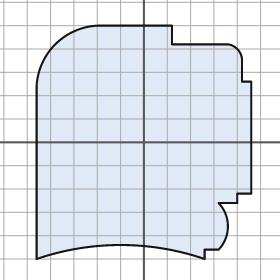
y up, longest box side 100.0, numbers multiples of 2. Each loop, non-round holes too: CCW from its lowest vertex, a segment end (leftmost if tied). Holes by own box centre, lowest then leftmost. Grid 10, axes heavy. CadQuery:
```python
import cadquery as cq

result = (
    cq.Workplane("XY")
    .moveTo(-46.0, -50.0)
    .threePointArc((-10.0, -44.0), (26.0, -50.0))
    .lineTo(26.0, -46.0)
    .lineTo(32.0, -46.0)
    .threePointArc((36.0, -36.0), (32.0, -26.0))
    .lineTo(40.0, -26.0)
    .lineTo(40.0, -22.0)
    .lineTo(46.0, -22.0)
    .lineTo(46.0, 26.0)
    .lineTo(42.0, 26.0)
    .lineTo(42.0, 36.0)
    .threePointArc((40.0, 40.0), (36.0, 42.0))
    .lineTo(12.0, 42.0)
    .lineTo(12.0, 50.0)
    .lineTo(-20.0, 50.0)
    .threePointArc((-38.0, 42.0), (-46.0, 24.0))
    .close()
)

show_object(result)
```